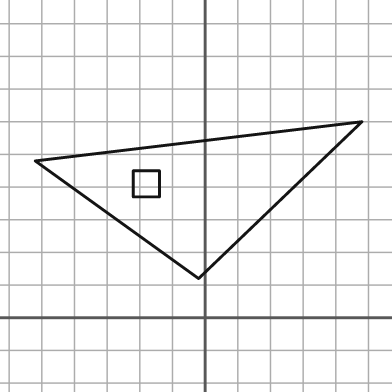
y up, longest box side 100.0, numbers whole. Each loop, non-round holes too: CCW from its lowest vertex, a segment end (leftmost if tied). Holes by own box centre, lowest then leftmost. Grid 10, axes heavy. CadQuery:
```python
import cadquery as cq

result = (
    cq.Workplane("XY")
    .moveTo(-2.0, 12.0)
    .lineTo(48.0, 60.0)
    .lineTo(-52.0, 48.0)
    .close()
    .moveTo(-22.0, 37.0)
    .lineTo(-14.0, 37.0)
    .lineTo(-14.0, 45.0)
    .lineTo(-22.0, 45.0)
    .close()
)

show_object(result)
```